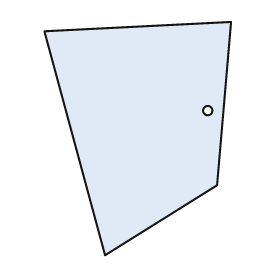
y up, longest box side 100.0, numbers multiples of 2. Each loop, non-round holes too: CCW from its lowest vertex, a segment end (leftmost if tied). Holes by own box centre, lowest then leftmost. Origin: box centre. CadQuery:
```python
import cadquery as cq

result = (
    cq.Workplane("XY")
    .moveTo(-14.0, -50.0)
    .lineTo(34.0, -20.0)
    .lineTo(40.0, 50.0)
    .lineTo(-40.0, 46.0)
    .close()
    .moveTo(30.0, 12.0)
    .circle(2.0)
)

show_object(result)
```